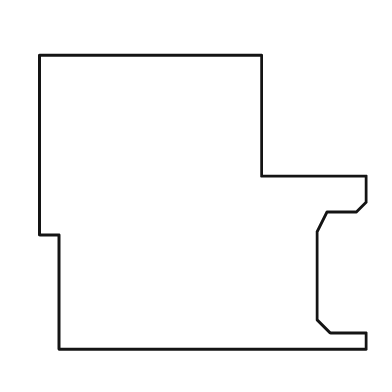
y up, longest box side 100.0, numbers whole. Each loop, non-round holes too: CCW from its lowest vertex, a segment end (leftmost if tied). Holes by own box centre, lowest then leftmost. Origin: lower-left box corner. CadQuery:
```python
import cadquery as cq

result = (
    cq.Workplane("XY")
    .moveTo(6.0, 0.0)
    .lineTo(100.0, 0.0)
    .lineTo(100.0, 5.0)
    .lineTo(89.0, 5.0)
    .lineTo(85.0, 9.0)
    .lineTo(85.0, 36.0)
    .lineTo(88.0, 42.0)
    .lineTo(97.0, 42.0)
    .lineTo(100.0, 45.0)
    .lineTo(100.0, 53.0)
    .lineTo(68.0, 53.0)
    .lineTo(68.0, 90.0)
    .lineTo(0.0, 90.0)
    .lineTo(0.0, 35.0)
    .lineTo(6.0, 35.0)
    .close()
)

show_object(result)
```